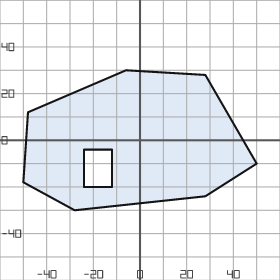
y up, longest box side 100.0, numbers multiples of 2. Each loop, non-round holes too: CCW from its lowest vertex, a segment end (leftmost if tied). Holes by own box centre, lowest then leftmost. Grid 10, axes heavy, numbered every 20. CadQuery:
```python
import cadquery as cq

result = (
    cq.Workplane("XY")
    .moveTo(-28.0, -30.0)
    .lineTo(28.0, -24.0)
    .lineTo(50.0, -10.0)
    .lineTo(28.0, 28.0)
    .lineTo(-6.0, 30.0)
    .lineTo(-48.0, 12.0)
    .lineTo(-50.0, -18.0)
    .close()
    .moveTo(-24.0, -20.0)
    .lineTo(-12.0, -20.0)
    .lineTo(-12.0, -4.0)
    .lineTo(-24.0, -4.0)
    .close()
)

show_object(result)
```